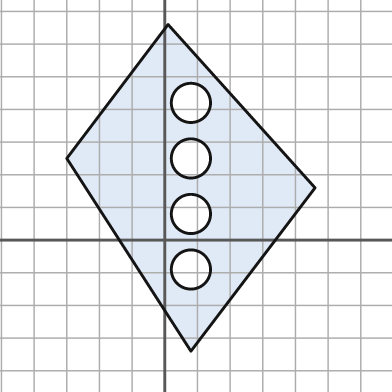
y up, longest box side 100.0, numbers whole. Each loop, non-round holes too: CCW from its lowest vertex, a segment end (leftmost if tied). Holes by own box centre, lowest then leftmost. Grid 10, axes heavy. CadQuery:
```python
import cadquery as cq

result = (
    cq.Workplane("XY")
    .moveTo(8.0, -34.0)
    .lineTo(46.0, 16.0)
    .lineTo(1.0, 66.0)
    .lineTo(-30.0, 25.0)
    .close()
    .moveTo(8.0, -9.0)
    .circle(6.0)
    .moveTo(8.0, 8.0)
    .circle(6.0)
    .moveTo(8.0, 25.0)
    .circle(6.0)
    .moveTo(8.0, 42.0)
    .circle(6.0)
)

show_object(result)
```